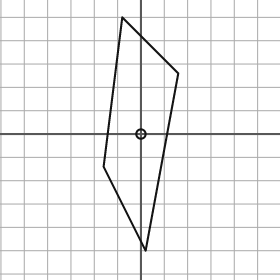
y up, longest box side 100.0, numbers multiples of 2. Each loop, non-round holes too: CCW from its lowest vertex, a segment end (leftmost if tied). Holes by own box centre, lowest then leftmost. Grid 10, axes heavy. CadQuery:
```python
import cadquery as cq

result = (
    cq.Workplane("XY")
    .moveTo(2.0, -50.0)
    .lineTo(16.0, 26.0)
    .lineTo(-8.0, 50.0)
    .lineTo(-16.0, -14.0)
    .close()
    .moveTo(0.0, 0.0)
    .circle(2.0)
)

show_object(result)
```